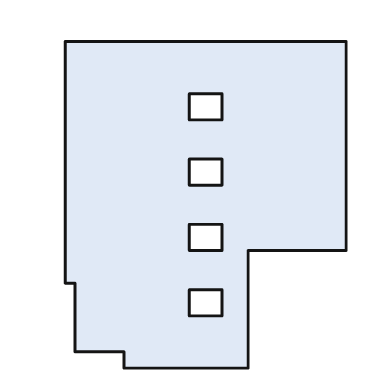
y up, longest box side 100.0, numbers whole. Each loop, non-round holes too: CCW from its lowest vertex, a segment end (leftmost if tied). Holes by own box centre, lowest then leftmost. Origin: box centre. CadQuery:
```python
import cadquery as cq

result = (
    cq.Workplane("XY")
    .moveTo(-25.0, -50.0)
    .lineTo(13.0, -50.0)
    .lineTo(13.0, -14.0)
    .lineTo(43.0, -14.0)
    .lineTo(43.0, 50.0)
    .lineTo(-43.0, 50.0)
    .lineTo(-43.0, -24.0)
    .lineTo(-40.0, -24.0)
    .lineTo(-40.0, -45.0)
    .lineTo(-25.0, -45.0)
    .close()
    .moveTo(-5.0, -34.0)
    .lineTo(5.0, -34.0)
    .lineTo(5.0, -26.0)
    .lineTo(-5.0, -26.0)
    .close()
    .moveTo(-5.0, -14.0)
    .lineTo(5.0, -14.0)
    .lineTo(5.0, -6.0)
    .lineTo(-5.0, -6.0)
    .close()
    .moveTo(-5.0, 6.0)
    .lineTo(5.0, 6.0)
    .lineTo(5.0, 14.0)
    .lineTo(-5.0, 14.0)
    .close()
    .moveTo(-5.0, 26.0)
    .lineTo(5.0, 26.0)
    .lineTo(5.0, 34.0)
    .lineTo(-5.0, 34.0)
    .close()
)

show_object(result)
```